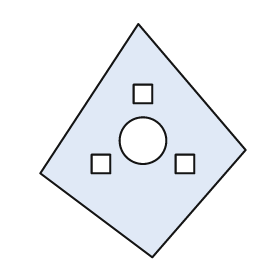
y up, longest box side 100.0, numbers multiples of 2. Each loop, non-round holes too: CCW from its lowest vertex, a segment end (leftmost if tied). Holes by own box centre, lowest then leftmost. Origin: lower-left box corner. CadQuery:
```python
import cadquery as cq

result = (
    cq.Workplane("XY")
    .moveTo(48.0, 0.0)
    .lineTo(88.0, 46.0)
    .lineTo(42.0, 100.0)
    .lineTo(0.0, 36.0)
    .close()
    .moveTo(22.0, 36.0)
    .lineTo(30.0, 36.0)
    .lineTo(30.0, 44.0)
    .lineTo(22.0, 44.0)
    .close()
    .moveTo(58.0, 36.0)
    .lineTo(66.0, 36.0)
    .lineTo(66.0, 44.0)
    .lineTo(58.0, 44.0)
    .close()
    .moveTo(44.0, 50.0)
    .circle(10.0)
    .moveTo(40.0, 66.0)
    .lineTo(48.0, 66.0)
    .lineTo(48.0, 74.0)
    .lineTo(40.0, 74.0)
    .close()
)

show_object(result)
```